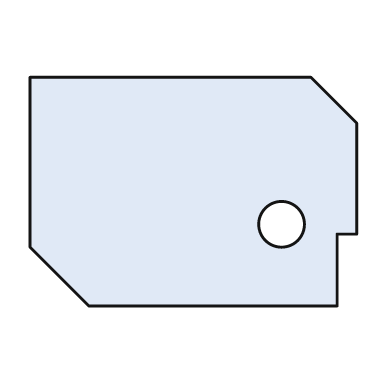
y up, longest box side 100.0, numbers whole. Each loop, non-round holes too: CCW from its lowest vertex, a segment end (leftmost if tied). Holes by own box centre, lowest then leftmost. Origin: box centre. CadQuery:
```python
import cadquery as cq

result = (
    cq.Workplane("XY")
    .moveTo(-32.0, -35.0)
    .lineTo(44.0, -35.0)
    .lineTo(44.0, -13.0)
    .lineTo(50.0, -13.0)
    .lineTo(50.0, 21.0)
    .lineTo(36.0, 35.0)
    .lineTo(-50.0, 35.0)
    .lineTo(-50.0, -17.0)
    .close()
    .moveTo(27.0, -10.0)
    .circle(7.0)
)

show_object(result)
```